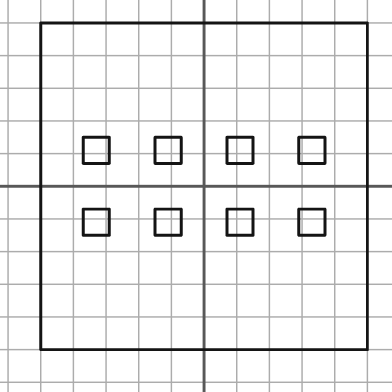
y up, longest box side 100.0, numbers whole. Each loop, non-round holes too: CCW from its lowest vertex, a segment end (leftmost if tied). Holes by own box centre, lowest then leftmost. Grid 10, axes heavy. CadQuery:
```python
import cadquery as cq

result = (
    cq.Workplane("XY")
    .moveTo(-50.0, -50.0)
    .lineTo(50.0, -50.0)
    .lineTo(50.0, 50.0)
    .lineTo(-50.0, 50.0)
    .close()
    .moveTo(-37.0, -15.0)
    .lineTo(-29.0, -15.0)
    .lineTo(-29.0, -7.0)
    .lineTo(-37.0, -7.0)
    .close()
    .moveTo(-15.0, -15.0)
    .lineTo(-7.0, -15.0)
    .lineTo(-7.0, -7.0)
    .lineTo(-15.0, -7.0)
    .close()
    .moveTo(7.0, -15.0)
    .lineTo(15.0, -15.0)
    .lineTo(15.0, -7.0)
    .lineTo(7.0, -7.0)
    .close()
    .moveTo(29.0, -15.0)
    .lineTo(37.0, -15.0)
    .lineTo(37.0, -7.0)
    .lineTo(29.0, -7.0)
    .close()
    .moveTo(-37.0, 7.0)
    .lineTo(-29.0, 7.0)
    .lineTo(-29.0, 15.0)
    .lineTo(-37.0, 15.0)
    .close()
    .moveTo(-15.0, 7.0)
    .lineTo(-7.0, 7.0)
    .lineTo(-7.0, 15.0)
    .lineTo(-15.0, 15.0)
    .close()
    .moveTo(7.0, 7.0)
    .lineTo(15.0, 7.0)
    .lineTo(15.0, 15.0)
    .lineTo(7.0, 15.0)
    .close()
    .moveTo(29.0, 7.0)
    .lineTo(37.0, 7.0)
    .lineTo(37.0, 15.0)
    .lineTo(29.0, 15.0)
    .close()
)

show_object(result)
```